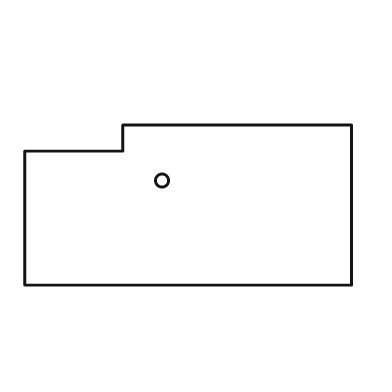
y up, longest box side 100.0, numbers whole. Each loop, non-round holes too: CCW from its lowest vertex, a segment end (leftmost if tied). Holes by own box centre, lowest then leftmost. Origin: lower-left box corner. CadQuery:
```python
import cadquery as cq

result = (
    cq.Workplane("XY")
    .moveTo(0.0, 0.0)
    .lineTo(100.0, 0.0)
    .lineTo(100.0, 49.0)
    .lineTo(30.0, 49.0)
    .lineTo(30.0, 41.0)
    .lineTo(0.0, 41.0)
    .close()
    .moveTo(42.0, 32.0)
    .circle(2.0)
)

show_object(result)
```